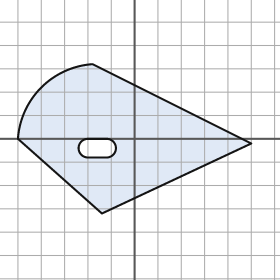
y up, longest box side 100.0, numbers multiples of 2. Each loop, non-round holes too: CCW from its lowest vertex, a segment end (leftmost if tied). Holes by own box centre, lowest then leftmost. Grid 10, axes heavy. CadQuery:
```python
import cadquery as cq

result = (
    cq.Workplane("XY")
    .moveTo(-14.0, -32.0)
    .lineTo(50.0, -2.0)
    .lineTo(-18.0, 32.0)
    .threePointArc((-40.0, 22.0), (-50.0, 0.0))
    .close()
    .moveTo(-20.0, -8.0)
    .lineTo(-12.0, -8.0)
    .threePointArc((-8.0, -4.0), (-12.0, 0.0))
    .lineTo(-20.0, 0.0)
    .threePointArc((-24.0, -4.0), (-20.0, -8.0))
    .close()
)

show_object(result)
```